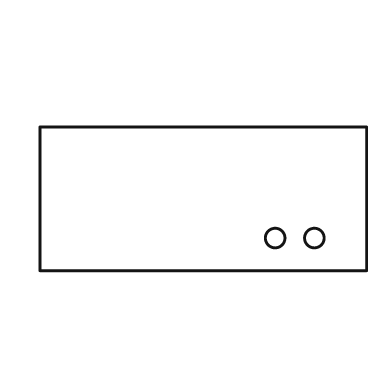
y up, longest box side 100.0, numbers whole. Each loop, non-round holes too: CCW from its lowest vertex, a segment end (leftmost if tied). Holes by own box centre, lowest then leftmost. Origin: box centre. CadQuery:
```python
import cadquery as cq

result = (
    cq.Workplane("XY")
    .moveTo(-50.0, -22.0)
    .lineTo(50.0, -22.0)
    .lineTo(50.0, 22.0)
    .lineTo(-50.0, 22.0)
    .close()
    .moveTo(22.0, -12.0)
    .circle(3.0)
    .moveTo(34.0, -12.0)
    .circle(3.0)
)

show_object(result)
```